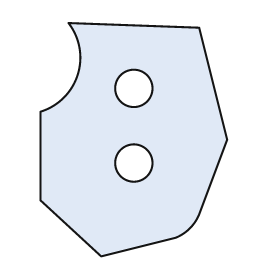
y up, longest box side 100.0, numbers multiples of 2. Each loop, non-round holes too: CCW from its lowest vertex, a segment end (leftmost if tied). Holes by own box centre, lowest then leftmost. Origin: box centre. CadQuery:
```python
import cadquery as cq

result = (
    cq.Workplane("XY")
    .moveTo(-14.0, -50.0)
    .lineTo(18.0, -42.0)
    .threePointArc((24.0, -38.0), (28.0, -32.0))
    .lineTo(40.0, 0.0)
    .lineTo(28.0, 48.0)
    .lineTo(-28.0, 50.0)
    .threePointArc((-24.0, 28.0), (-40.0, 12.0))
    .lineTo(-40.0, -26.0)
    .close()
    .moveTo(0.0, -10.0)
    .circle(8.0)
    .moveTo(0.0, 22.0)
    .circle(8.0)
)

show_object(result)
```